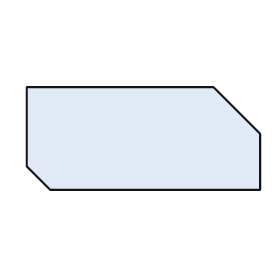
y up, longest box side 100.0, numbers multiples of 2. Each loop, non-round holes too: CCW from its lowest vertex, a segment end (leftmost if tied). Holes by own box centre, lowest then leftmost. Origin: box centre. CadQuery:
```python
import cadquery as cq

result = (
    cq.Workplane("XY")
    .moveTo(-40.0, -22.0)
    .lineTo(50.0, -22.0)
    .lineTo(50.0, 2.0)
    .lineTo(30.0, 22.0)
    .lineTo(-50.0, 22.0)
    .lineTo(-50.0, -12.0)
    .close()
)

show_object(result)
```